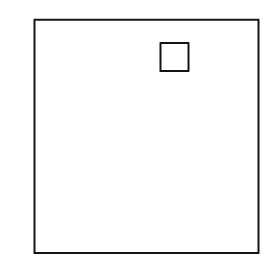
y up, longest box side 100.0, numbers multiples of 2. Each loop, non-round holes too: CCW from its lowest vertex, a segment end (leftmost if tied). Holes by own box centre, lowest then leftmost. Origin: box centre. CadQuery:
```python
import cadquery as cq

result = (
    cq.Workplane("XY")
    .moveTo(-48.0, -50.0)
    .lineTo(48.0, -50.0)
    .lineTo(48.0, 50.0)
    .lineTo(-48.0, 50.0)
    .close()
    .moveTo(6.0, 28.0)
    .lineTo(18.0, 28.0)
    .lineTo(18.0, 40.0)
    .lineTo(6.0, 40.0)
    .close()
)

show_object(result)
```